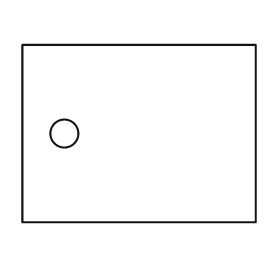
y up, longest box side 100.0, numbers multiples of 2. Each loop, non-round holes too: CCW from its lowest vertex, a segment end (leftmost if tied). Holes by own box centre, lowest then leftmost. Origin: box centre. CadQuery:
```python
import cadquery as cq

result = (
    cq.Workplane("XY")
    .moveTo(-50.0, -38.0)
    .lineTo(50.0, -38.0)
    .lineTo(50.0, 38.0)
    .lineTo(-50.0, 38.0)
    .close()
    .moveTo(-32.0, 0.0)
    .circle(6.0)
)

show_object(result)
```